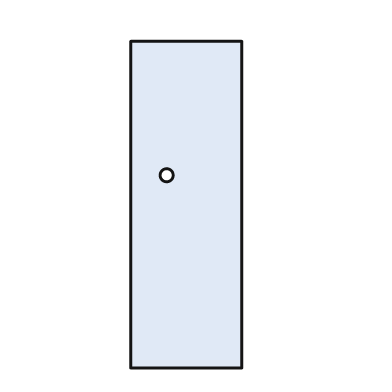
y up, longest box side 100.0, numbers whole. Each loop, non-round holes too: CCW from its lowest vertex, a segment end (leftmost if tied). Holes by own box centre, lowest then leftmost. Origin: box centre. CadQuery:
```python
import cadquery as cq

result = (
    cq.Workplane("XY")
    .moveTo(-17.0, -50.0)
    .lineTo(17.0, -50.0)
    .lineTo(17.0, 50.0)
    .lineTo(-17.0, 50.0)
    .close()
    .moveTo(-6.0, 9.0)
    .circle(2.0)
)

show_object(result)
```